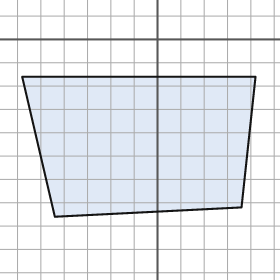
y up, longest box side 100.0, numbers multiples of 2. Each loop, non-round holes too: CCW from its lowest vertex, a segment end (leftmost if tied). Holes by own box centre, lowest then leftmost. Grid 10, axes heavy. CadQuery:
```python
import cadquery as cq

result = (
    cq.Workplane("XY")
    .moveTo(-44.0, -76.0)
    .lineTo(36.0, -72.0)
    .lineTo(42.0, -16.0)
    .lineTo(-58.0, -16.0)
    .close()
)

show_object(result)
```